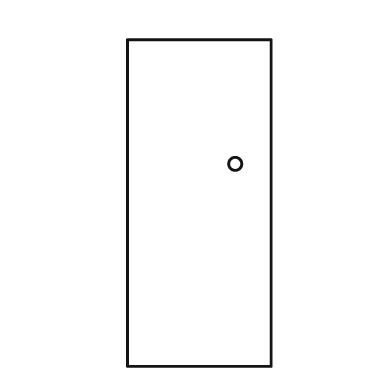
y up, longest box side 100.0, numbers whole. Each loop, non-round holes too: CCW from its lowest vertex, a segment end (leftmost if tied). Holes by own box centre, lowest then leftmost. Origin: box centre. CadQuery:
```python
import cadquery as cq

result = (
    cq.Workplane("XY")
    .moveTo(-22.0, -50.0)
    .lineTo(22.0, -50.0)
    .lineTo(22.0, 50.0)
    .lineTo(-22.0, 50.0)
    .close()
    .moveTo(11.0, 12.0)
    .circle(2.0)
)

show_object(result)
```